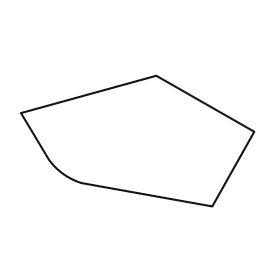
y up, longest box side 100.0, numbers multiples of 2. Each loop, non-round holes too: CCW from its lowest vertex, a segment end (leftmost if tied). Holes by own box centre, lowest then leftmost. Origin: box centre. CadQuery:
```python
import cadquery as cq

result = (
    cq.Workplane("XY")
    .moveTo(32.0, -28.0)
    .lineTo(50.0, 4.0)
    .lineTo(8.0, 28.0)
    .lineTo(-50.0, 12.0)
    .lineTo(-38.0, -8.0)
    .threePointArc((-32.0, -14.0), (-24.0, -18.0))
    .close()
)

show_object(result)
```